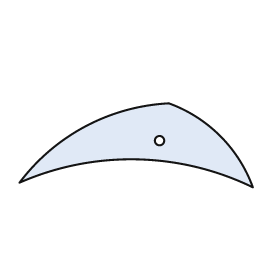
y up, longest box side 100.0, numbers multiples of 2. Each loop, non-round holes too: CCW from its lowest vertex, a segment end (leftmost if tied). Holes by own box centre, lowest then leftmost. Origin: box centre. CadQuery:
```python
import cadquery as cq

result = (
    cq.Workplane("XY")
    .moveTo(50.0, -18.0)
    .threePointArc((36.0, 4.0), (14.0, 18.0))
    .threePointArc((-22.0, 8.0), (-50.0, -16.0))
    .threePointArc((0.0, -6.0), (50.0, -18.0))
    .close()
    .moveTo(10.0, 2.0)
    .circle(2.0)
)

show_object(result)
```